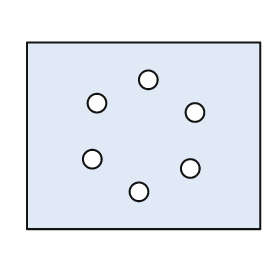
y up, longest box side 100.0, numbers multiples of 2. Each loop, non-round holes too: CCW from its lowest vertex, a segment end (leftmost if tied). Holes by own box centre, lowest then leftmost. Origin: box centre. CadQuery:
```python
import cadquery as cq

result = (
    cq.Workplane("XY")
    .moveTo(-50.0, -40.0)
    .lineTo(50.0, -40.0)
    .lineTo(50.0, 40.0)
    .lineTo(-50.0, 40.0)
    .close()
    .moveTo(-2.0, -24.0)
    .circle(4.0)
    .moveTo(20.0, -14.0)
    .circle(4.0)
    .moveTo(-22.0, -10.0)
    .circle(4.0)
    .moveTo(22.0, 10.0)
    .circle(4.0)
    .moveTo(-20.0, 14.0)
    .circle(4.0)
    .moveTo(2.0, 24.0)
    .circle(4.0)
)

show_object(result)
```